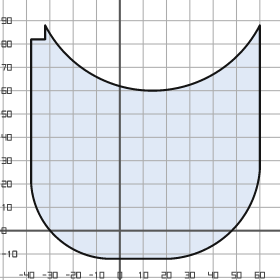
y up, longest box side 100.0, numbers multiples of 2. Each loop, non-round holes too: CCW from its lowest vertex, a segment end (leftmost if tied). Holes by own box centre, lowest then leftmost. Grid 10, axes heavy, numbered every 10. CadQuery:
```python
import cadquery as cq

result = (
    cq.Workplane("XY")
    .moveTo(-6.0, -12.0)
    .lineTo(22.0, -12.0)
    .threePointArc((48.0, 0.0), (60.0, 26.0))
    .lineTo(60.0, 88.0)
    .threePointArc((14.0, 60.0), (-32.0, 88.0))
    .lineTo(-32.0, 82.0)
    .lineTo(-38.0, 82.0)
    .lineTo(-38.0, 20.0)
    .threePointArc((-28.0, -2.0), (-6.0, -12.0))
    .close()
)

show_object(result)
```